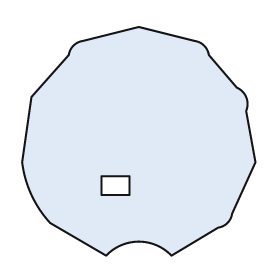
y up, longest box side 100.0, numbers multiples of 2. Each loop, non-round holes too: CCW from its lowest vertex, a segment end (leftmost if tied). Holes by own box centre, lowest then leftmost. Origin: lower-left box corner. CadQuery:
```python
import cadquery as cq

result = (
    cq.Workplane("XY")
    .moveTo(36.0, 0.0)
    .threePointArc((50.0, 6.0), (64.0, 0.0))
    .lineTo(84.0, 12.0)
    .threePointArc((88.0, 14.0), (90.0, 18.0))
    .lineTo(100.0, 40.0)
    .lineTo(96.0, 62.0)
    .threePointArc((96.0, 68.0), (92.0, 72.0))
    .lineTo(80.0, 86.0)
    .threePointArc((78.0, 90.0), (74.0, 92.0))
    .lineTo(50.0, 98.0)
    .lineTo(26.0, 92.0)
    .threePointArc((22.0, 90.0), (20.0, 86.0))
    .lineTo(4.0, 68.0)
    .lineTo(0.0, 40.0)
    .threePointArc((4.0, 26.0), (12.0, 14.0))
    .close()
    .moveTo(34.0, 26.0)
    .lineTo(46.0, 26.0)
    .lineTo(46.0, 34.0)
    .lineTo(34.0, 34.0)
    .close()
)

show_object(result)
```